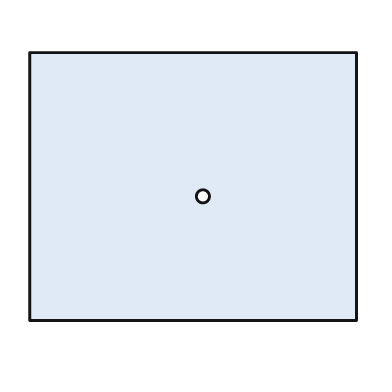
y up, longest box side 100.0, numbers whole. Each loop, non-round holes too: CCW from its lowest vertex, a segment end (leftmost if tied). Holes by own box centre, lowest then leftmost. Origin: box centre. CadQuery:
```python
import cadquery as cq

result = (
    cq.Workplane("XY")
    .moveTo(-50.0, -41.0)
    .lineTo(50.0, -41.0)
    .lineTo(50.0, 41.0)
    .lineTo(-50.0, 41.0)
    .close()
    .moveTo(3.0, -3.0)
    .circle(2.0)
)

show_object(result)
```